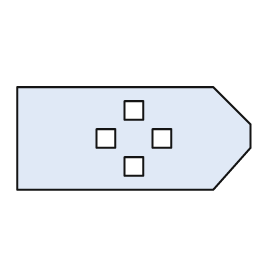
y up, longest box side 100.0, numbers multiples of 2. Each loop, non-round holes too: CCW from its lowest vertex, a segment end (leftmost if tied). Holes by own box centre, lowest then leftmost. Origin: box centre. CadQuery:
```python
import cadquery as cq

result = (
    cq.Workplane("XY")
    .moveTo(-50.0, -22.0)
    .lineTo(34.0, -22.0)
    .lineTo(50.0, -4.0)
    .lineTo(50.0, 6.0)
    .lineTo(34.0, 22.0)
    .lineTo(-50.0, 22.0)
    .close()
    .moveTo(-4.0, -16.0)
    .lineTo(4.0, -16.0)
    .lineTo(4.0, -8.0)
    .lineTo(-4.0, -8.0)
    .close()
    .moveTo(-16.0, -4.0)
    .lineTo(-8.0, -4.0)
    .lineTo(-8.0, 4.0)
    .lineTo(-16.0, 4.0)
    .close()
    .moveTo(8.0, -4.0)
    .lineTo(16.0, -4.0)
    .lineTo(16.0, 4.0)
    .lineTo(8.0, 4.0)
    .close()
    .moveTo(-4.0, 8.0)
    .lineTo(4.0, 8.0)
    .lineTo(4.0, 16.0)
    .lineTo(-4.0, 16.0)
    .close()
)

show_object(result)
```